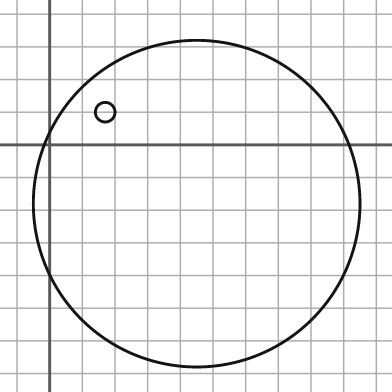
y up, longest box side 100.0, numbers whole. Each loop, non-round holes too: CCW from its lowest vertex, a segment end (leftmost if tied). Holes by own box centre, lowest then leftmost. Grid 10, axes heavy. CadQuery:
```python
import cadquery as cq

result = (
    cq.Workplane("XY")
    .moveTo(45.0, -18.0)
    .circle(50.0)
    .moveTo(17.0, 10.0)
    .circle(3.0)
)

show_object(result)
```